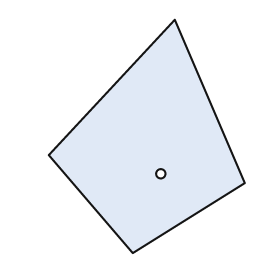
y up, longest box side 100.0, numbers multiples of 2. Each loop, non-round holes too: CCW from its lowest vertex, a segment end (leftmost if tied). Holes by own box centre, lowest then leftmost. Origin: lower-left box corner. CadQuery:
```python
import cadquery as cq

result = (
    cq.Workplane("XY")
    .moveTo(36.0, 0.0)
    .lineTo(84.0, 30.0)
    .lineTo(54.0, 100.0)
    .lineTo(0.0, 42.0)
    .close()
    .moveTo(48.0, 34.0)
    .circle(2.0)
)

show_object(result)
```